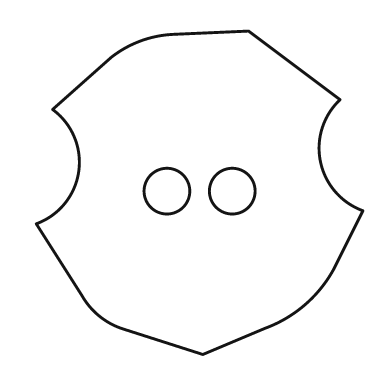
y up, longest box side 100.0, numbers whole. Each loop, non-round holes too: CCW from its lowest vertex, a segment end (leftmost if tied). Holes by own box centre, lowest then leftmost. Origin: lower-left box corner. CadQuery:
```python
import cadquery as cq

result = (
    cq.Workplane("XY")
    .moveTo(51.0, 0.0)
    .lineTo(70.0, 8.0)
    .threePointArc((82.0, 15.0), (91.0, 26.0))
    .lineTo(100.0, 44.0)
    .threePointArc((87.0, 59.0), (93.0, 78.0))
    .lineTo(65.0, 99.0)
    .lineTo(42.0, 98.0)
    .threePointArc((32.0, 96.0), (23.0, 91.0))
    .lineTo(5.0, 75.0)
    .threePointArc((13.0, 56.0), (0.0, 40.0))
    .lineTo(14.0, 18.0)
    .threePointArc((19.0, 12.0), (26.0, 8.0))
    .close()
    .moveTo(40.0, 50.0)
    .circle(7.0)
    .moveTo(60.0, 50.0)
    .circle(7.0)
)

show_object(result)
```